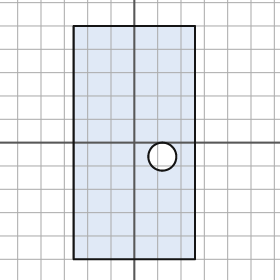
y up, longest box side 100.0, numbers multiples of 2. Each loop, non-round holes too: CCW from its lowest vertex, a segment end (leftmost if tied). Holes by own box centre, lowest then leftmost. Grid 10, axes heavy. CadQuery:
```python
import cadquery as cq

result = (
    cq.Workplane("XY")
    .moveTo(-26.0, -50.0)
    .lineTo(26.0, -50.0)
    .lineTo(26.0, 50.0)
    .lineTo(-26.0, 50.0)
    .close()
    .moveTo(12.0, -6.0)
    .circle(6.0)
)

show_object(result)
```